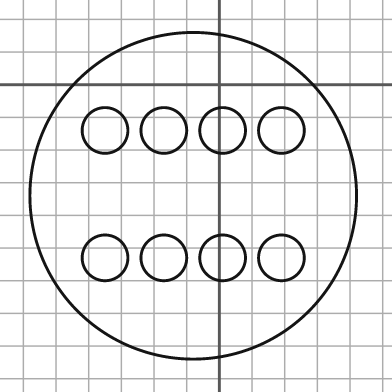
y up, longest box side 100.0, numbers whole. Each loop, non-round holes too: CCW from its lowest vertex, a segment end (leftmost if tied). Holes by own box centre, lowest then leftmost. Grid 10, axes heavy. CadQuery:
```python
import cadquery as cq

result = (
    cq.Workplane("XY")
    .moveTo(-8.0, -34.0)
    .circle(50.0)
    .moveTo(-35.0, -53.0)
    .circle(7.0)
    .moveTo(-17.0, -53.0)
    .circle(7.0)
    .moveTo(1.0, -53.0)
    .circle(7.0)
    .moveTo(19.0, -53.0)
    .circle(7.0)
    .moveTo(-35.0, -14.0)
    .circle(7.0)
    .moveTo(-17.0, -14.0)
    .circle(7.0)
    .moveTo(1.0, -14.0)
    .circle(7.0)
    .moveTo(19.0, -14.0)
    .circle(7.0)
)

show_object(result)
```